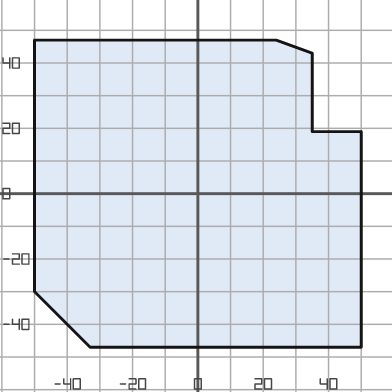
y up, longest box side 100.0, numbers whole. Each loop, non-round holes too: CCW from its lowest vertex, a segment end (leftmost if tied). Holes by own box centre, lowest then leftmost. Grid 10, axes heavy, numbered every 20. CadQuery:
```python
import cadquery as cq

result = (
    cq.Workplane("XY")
    .moveTo(-33.0, -47.0)
    .lineTo(50.0, -47.0)
    .lineTo(50.0, 19.0)
    .lineTo(35.0, 19.0)
    .lineTo(35.0, 43.0)
    .lineTo(24.0, 47.0)
    .lineTo(-50.0, 47.0)
    .lineTo(-50.0, -30.0)
    .close()
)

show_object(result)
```